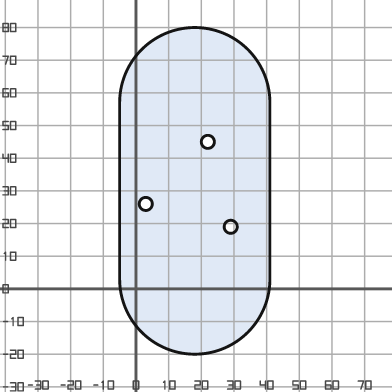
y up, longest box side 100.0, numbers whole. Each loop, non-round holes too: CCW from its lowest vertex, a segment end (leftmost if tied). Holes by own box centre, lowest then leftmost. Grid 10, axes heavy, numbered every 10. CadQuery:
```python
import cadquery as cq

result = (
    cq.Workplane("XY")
    .moveTo(-5.0, 3.0)
    .threePointArc((18.0, -20.0), (41.0, 3.0))
    .lineTo(41.0, 57.0)
    .threePointArc((18.0, 80.0), (-5.0, 57.0))
    .close()
    .moveTo(29.0, 19.0)
    .circle(2.0)
    .moveTo(3.0, 26.0)
    .circle(2.0)
    .moveTo(22.0, 45.0)
    .circle(2.0)
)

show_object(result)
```